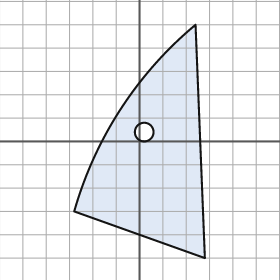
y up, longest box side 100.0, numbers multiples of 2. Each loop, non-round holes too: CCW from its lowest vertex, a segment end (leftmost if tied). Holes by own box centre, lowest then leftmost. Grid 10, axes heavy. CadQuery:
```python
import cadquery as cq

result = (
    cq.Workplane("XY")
    .moveTo(28.0, -50.0)
    .lineTo(24.0, 50.0)
    .threePointArc((-8.0, 14.0), (-28.0, -30.0))
    .close()
    .moveTo(2.0, 4.0)
    .circle(4.0)
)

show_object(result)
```